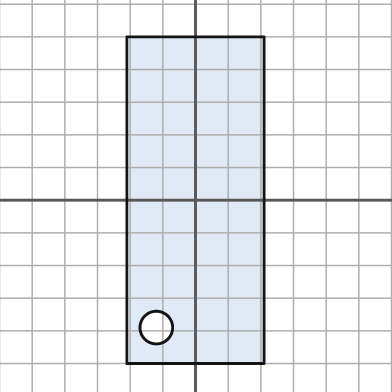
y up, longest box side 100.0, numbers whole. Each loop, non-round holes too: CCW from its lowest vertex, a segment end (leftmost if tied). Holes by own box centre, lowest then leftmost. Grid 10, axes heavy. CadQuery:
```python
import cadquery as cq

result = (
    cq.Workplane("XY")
    .moveTo(-21.0, -50.0)
    .lineTo(21.0, -50.0)
    .lineTo(21.0, 50.0)
    .lineTo(-21.0, 50.0)
    .close()
    .moveTo(-12.0, -39.0)
    .circle(5.0)
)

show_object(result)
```